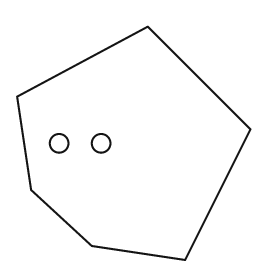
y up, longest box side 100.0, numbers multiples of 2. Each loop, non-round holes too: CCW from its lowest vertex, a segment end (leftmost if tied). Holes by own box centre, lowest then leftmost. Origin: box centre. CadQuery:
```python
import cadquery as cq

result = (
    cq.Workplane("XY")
    .moveTo(22.0, -50.0)
    .lineTo(50.0, 6.0)
    .lineTo(6.0, 50.0)
    .lineTo(-50.0, 20.0)
    .lineTo(-44.0, -20.0)
    .lineTo(-18.0, -44.0)
    .close()
    .moveTo(-32.0, 0.0)
    .circle(4.0)
    .moveTo(-14.0, 0.0)
    .circle(4.0)
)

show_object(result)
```